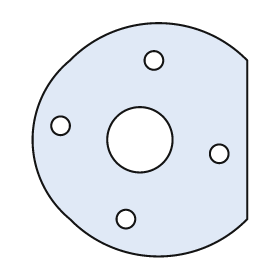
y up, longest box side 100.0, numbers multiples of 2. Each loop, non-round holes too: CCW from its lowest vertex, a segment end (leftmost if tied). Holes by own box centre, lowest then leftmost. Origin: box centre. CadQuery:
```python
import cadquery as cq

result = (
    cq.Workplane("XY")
    .moveTo(-30.0, -34.0)
    .threePointArc((8.0, -50.0), (46.0, -34.0))
    .lineTo(46.0, 34.0)
    .threePointArc((8.0, 50.0), (-30.0, 34.0))
    .threePointArc((-46.0, 0.0), (-30.0, -34.0))
    .close()
    .moveTo(-6.0, -34.0)
    .circle(4.0)
    .moveTo(34.0, -6.0)
    .circle(4.0)
    .moveTo(0.0, 0.0)
    .circle(14.0)
    .moveTo(-34.0, 6.0)
    .circle(4.0)
    .moveTo(6.0, 34.0)
    .circle(4.0)
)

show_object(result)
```